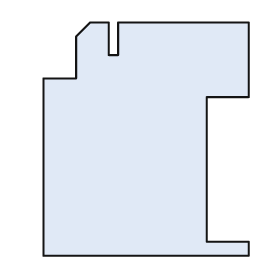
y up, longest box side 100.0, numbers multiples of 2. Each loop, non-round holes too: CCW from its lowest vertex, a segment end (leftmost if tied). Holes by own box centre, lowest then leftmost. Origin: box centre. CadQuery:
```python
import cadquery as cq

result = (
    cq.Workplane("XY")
    .moveTo(-44.0, -50.0)
    .lineTo(44.0, -50.0)
    .lineTo(44.0, -44.0)
    .lineTo(26.0, -44.0)
    .lineTo(26.0, 18.0)
    .lineTo(44.0, 18.0)
    .lineTo(44.0, 50.0)
    .lineTo(-12.0, 50.0)
    .lineTo(-12.0, 36.0)
    .lineTo(-16.0, 36.0)
    .lineTo(-16.0, 50.0)
    .lineTo(-24.0, 50.0)
    .lineTo(-30.0, 44.0)
    .lineTo(-30.0, 26.0)
    .lineTo(-44.0, 26.0)
    .close()
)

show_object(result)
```